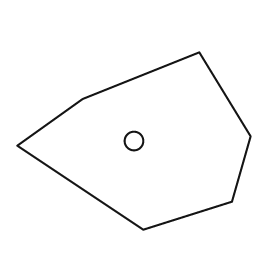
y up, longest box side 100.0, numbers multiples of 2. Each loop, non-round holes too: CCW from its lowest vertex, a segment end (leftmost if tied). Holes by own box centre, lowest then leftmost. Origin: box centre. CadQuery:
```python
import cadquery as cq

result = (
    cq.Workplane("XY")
    .moveTo(4.0, -38.0)
    .lineTo(42.0, -26.0)
    .lineTo(50.0, 2.0)
    .lineTo(28.0, 38.0)
    .lineTo(-22.0, 18.0)
    .lineTo(-50.0, -2.0)
    .close()
    .moveTo(0.0, 0.0)
    .circle(4.0)
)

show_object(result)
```